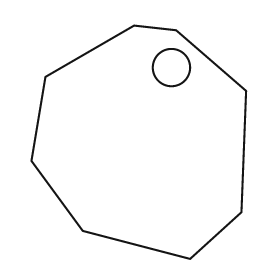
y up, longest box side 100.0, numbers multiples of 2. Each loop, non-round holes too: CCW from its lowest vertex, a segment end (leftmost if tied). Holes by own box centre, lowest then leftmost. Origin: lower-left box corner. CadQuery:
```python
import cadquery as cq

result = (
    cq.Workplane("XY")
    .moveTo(68.0, 0.0)
    .lineTo(90.0, 20.0)
    .lineTo(92.0, 72.0)
    .lineTo(62.0, 98.0)
    .lineTo(44.0, 100.0)
    .lineTo(6.0, 78.0)
    .lineTo(0.0, 42.0)
    .lineTo(22.0, 12.0)
    .close()
    .moveTo(60.0, 82.0)
    .circle(8.0)
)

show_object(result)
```